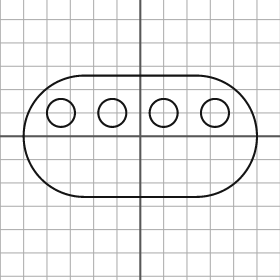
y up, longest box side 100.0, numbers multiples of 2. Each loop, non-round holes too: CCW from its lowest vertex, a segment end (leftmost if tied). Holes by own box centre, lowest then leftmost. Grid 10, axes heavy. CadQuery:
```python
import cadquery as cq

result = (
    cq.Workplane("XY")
    .moveTo(-24.0, -26.0)
    .lineTo(24.0, -26.0)
    .threePointArc((50.0, 0.0), (24.0, 26.0))
    .lineTo(-24.0, 26.0)
    .threePointArc((-50.0, 0.0), (-24.0, -26.0))
    .close()
    .moveTo(-34.0, 10.0)
    .circle(6.0)
    .moveTo(-12.0, 10.0)
    .circle(6.0)
    .moveTo(10.0, 10.0)
    .circle(6.0)
    .moveTo(32.0, 10.0)
    .circle(6.0)
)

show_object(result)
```